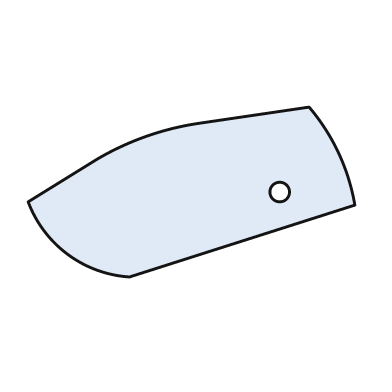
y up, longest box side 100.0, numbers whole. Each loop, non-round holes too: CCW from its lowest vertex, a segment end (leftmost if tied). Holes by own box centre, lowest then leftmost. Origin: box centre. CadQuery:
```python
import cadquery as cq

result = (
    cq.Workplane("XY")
    .moveTo(-19.0, -26.0)
    .lineTo(50.0, -4.0)
    .threePointArc((45.0, 12.0), (36.0, 26.0))
    .lineTo(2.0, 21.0)
    .threePointArc((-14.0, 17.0), (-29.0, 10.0))
    .lineTo(-50.0, -3.0)
    .threePointArc((-38.0, -19.0), (-19.0, -26.0))
    .close()
    .moveTo(27.0, 0.0)
    .circle(3.0)
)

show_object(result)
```